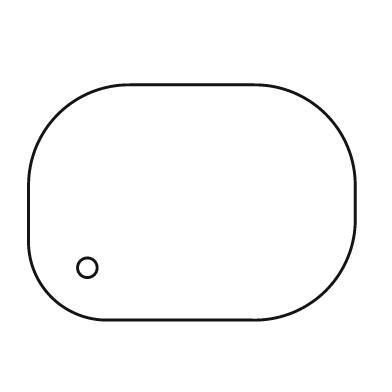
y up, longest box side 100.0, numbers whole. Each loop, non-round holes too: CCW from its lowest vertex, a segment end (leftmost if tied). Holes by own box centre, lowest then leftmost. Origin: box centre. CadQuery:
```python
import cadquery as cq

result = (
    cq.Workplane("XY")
    .moveTo(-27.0, -36.0)
    .lineTo(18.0, -36.0)
    .threePointArc((41.0, -27.0), (50.0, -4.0))
    .lineTo(50.0, 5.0)
    .threePointArc((41.0, 27.0), (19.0, 36.0))
    .lineTo(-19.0, 36.0)
    .threePointArc((-41.0, 27.0), (-50.0, 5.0))
    .lineTo(-50.0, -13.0)
    .threePointArc((-43.0, -29.0), (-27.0, -36.0))
    .close()
    .moveTo(-32.0, -20.0)
    .circle(3.0)
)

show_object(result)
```